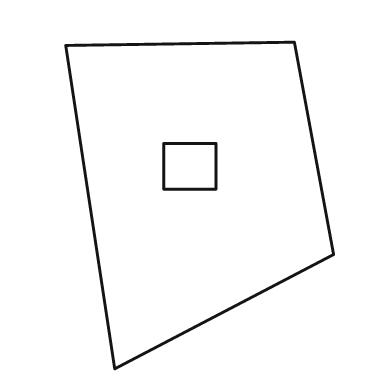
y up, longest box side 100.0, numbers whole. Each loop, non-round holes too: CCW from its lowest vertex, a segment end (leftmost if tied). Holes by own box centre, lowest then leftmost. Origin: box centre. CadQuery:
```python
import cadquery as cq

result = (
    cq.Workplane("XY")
    .moveTo(-26.0, -50.0)
    .lineTo(41.0, -15.0)
    .lineTo(29.0, 50.0)
    .lineTo(-41.0, 49.0)
    .close()
    .moveTo(-11.0, 5.0)
    .lineTo(5.0, 5.0)
    .lineTo(5.0, 19.0)
    .lineTo(-11.0, 19.0)
    .close()
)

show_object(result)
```